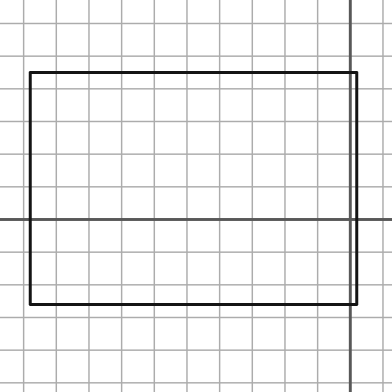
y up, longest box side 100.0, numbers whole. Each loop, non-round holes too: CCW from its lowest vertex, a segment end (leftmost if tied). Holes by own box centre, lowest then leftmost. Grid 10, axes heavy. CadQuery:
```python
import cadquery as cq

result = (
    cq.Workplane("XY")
    .moveTo(-98.0, -26.0)
    .lineTo(2.0, -26.0)
    .lineTo(2.0, 45.0)
    .lineTo(-98.0, 45.0)
    .close()
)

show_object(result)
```